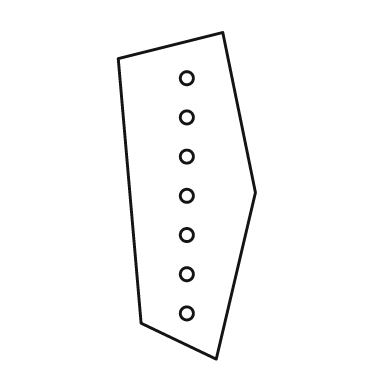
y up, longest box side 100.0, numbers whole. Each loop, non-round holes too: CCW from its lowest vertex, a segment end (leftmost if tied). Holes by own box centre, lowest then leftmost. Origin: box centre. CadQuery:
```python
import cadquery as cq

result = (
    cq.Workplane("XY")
    .moveTo(9.0, -50.0)
    .lineTo(21.0, 1.0)
    .lineTo(11.0, 50.0)
    .lineTo(-21.0, 42.0)
    .lineTo(-14.0, -39.0)
    .close()
    .moveTo(0.0, -36.0)
    .circle(2.0)
    .moveTo(0.0, -24.0)
    .circle(2.0)
    .moveTo(0.0, -12.0)
    .circle(2.0)
    .moveTo(0.0, 0.0)
    .circle(2.0)
    .moveTo(0.0, 12.0)
    .circle(2.0)
    .moveTo(0.0, 24.0)
    .circle(2.0)
    .moveTo(0.0, 36.0)
    .circle(2.0)
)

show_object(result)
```